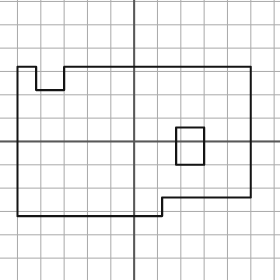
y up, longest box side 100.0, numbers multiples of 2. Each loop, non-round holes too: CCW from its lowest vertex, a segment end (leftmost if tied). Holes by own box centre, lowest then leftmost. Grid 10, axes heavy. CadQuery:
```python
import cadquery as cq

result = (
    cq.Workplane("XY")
    .moveTo(-50.0, -32.0)
    .lineTo(12.0, -32.0)
    .lineTo(12.0, -24.0)
    .lineTo(50.0, -24.0)
    .lineTo(50.0, 32.0)
    .lineTo(-30.0, 32.0)
    .lineTo(-30.0, 22.0)
    .lineTo(-42.0, 22.0)
    .lineTo(-42.0, 32.0)
    .lineTo(-50.0, 32.0)
    .close()
    .moveTo(18.0, -10.0)
    .lineTo(30.0, -10.0)
    .lineTo(30.0, 6.0)
    .lineTo(18.0, 6.0)
    .close()
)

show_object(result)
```